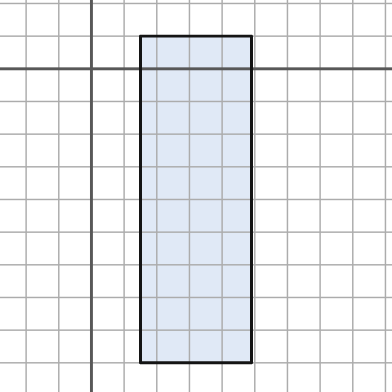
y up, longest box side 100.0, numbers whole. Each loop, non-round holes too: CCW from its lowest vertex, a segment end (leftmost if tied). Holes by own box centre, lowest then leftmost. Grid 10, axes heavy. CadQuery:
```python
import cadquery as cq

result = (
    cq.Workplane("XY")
    .moveTo(15.0, -90.0)
    .lineTo(49.0, -90.0)
    .lineTo(49.0, 10.0)
    .lineTo(15.0, 10.0)
    .close()
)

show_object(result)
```